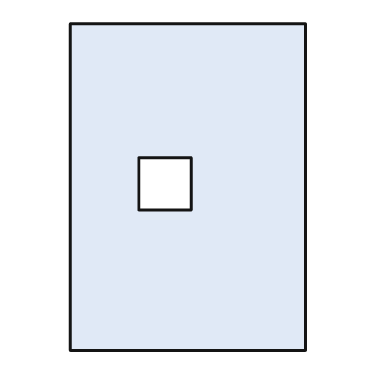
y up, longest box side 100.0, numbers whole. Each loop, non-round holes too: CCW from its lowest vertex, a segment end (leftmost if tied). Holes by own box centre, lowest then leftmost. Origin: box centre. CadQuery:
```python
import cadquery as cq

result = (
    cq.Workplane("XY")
    .moveTo(-36.0, -50.0)
    .lineTo(36.0, -50.0)
    .lineTo(36.0, 50.0)
    .lineTo(-36.0, 50.0)
    .close()
    .moveTo(-15.0, -7.0)
    .lineTo(1.0, -7.0)
    .lineTo(1.0, 9.0)
    .lineTo(-15.0, 9.0)
    .close()
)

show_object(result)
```